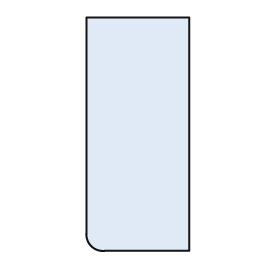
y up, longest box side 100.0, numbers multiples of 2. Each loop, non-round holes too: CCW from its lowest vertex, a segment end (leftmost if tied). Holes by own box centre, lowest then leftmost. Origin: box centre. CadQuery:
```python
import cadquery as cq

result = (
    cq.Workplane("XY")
    .moveTo(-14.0, -50.0)
    .lineTo(22.0, -50.0)
    .lineTo(22.0, 50.0)
    .lineTo(-22.0, 50.0)
    .lineTo(-22.0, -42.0)
    .threePointArc((-20.0, -48.0), (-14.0, -50.0))
    .close()
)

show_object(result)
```